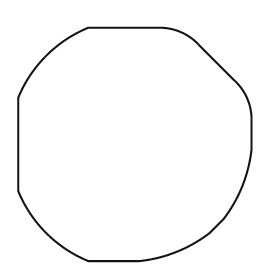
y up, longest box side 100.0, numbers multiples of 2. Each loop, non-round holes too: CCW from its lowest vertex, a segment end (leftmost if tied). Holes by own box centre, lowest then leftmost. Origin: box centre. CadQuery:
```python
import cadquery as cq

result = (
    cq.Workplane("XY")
    .moveTo(-20.0, -50.0)
    .lineTo(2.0, -50.0)
    .threePointArc((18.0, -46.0), (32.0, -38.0))
    .lineTo(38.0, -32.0)
    .threePointArc((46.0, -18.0), (50.0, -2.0))
    .lineTo(50.0, 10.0)
    .threePointArc((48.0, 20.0), (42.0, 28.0))
    .lineTo(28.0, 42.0)
    .threePointArc((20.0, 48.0), (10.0, 50.0))
    .lineTo(-20.0, 50.0)
    .threePointArc((-38.0, 38.0), (-50.0, 20.0))
    .lineTo(-50.0, -20.0)
    .threePointArc((-38.0, -38.0), (-20.0, -50.0))
    .close()
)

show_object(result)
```